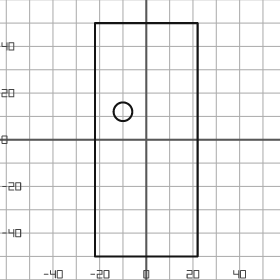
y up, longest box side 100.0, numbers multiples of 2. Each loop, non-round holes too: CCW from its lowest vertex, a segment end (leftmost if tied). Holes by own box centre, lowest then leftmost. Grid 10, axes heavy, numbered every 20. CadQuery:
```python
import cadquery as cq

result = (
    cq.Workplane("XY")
    .moveTo(-22.0, -50.0)
    .lineTo(22.0, -50.0)
    .lineTo(22.0, 50.0)
    .lineTo(-22.0, 50.0)
    .close()
    .moveTo(-10.0, 12.0)
    .circle(4.0)
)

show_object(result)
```